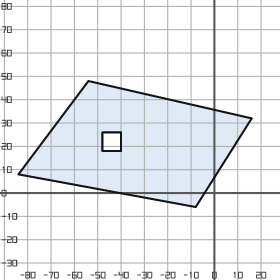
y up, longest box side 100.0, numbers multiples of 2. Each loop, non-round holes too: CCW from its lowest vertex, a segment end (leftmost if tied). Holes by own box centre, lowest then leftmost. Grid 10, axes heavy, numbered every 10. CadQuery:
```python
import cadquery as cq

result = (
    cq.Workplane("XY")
    .moveTo(-8.0, -6.0)
    .lineTo(16.0, 32.0)
    .lineTo(-54.0, 48.0)
    .lineTo(-84.0, 8.0)
    .close()
    .moveTo(-48.0, 18.0)
    .lineTo(-40.0, 18.0)
    .lineTo(-40.0, 26.0)
    .lineTo(-48.0, 26.0)
    .close()
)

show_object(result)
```